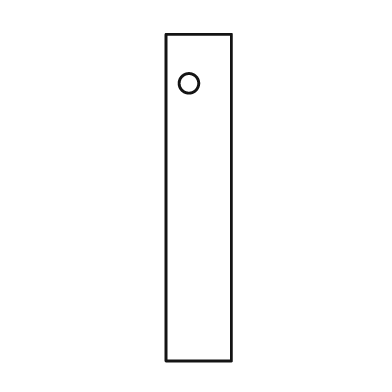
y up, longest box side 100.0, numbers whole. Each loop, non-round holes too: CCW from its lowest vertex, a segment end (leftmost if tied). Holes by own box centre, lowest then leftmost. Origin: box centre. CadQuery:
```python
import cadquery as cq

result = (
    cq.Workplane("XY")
    .moveTo(-10.0, -50.0)
    .lineTo(10.0, -50.0)
    .lineTo(10.0, 50.0)
    .lineTo(-10.0, 50.0)
    .close()
    .moveTo(-3.0, 35.0)
    .circle(3.0)
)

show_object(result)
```